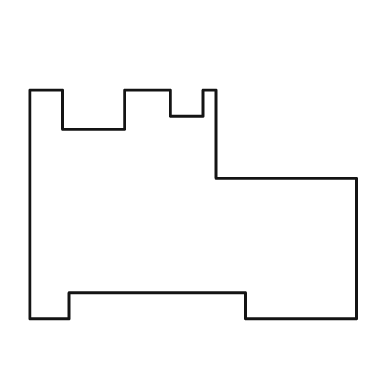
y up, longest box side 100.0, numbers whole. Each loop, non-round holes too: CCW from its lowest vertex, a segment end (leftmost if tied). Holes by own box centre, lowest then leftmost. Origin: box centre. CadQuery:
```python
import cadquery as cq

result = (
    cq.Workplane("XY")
    .moveTo(-50.0, -35.0)
    .lineTo(-38.0, -35.0)
    .lineTo(-38.0, -27.0)
    .lineTo(16.0, -27.0)
    .lineTo(16.0, -35.0)
    .lineTo(50.0, -35.0)
    .lineTo(50.0, 8.0)
    .lineTo(7.0, 8.0)
    .lineTo(7.0, 35.0)
    .lineTo(3.0, 35.0)
    .lineTo(3.0, 27.0)
    .lineTo(-7.0, 27.0)
    .lineTo(-7.0, 35.0)
    .lineTo(-21.0, 35.0)
    .lineTo(-21.0, 23.0)
    .lineTo(-40.0, 23.0)
    .lineTo(-40.0, 35.0)
    .lineTo(-50.0, 35.0)
    .close()
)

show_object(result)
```